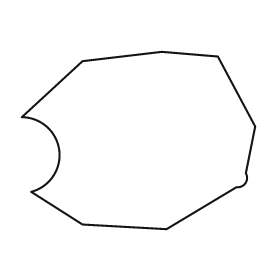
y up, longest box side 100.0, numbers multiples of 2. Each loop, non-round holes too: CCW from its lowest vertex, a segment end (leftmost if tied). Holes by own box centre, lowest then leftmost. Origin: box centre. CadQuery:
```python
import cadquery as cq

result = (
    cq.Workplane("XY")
    .moveTo(12.0, -38.0)
    .lineTo(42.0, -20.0)
    .threePointArc((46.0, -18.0), (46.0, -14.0))
    .lineTo(50.0, 6.0)
    .lineTo(34.0, 36.0)
    .lineTo(10.0, 38.0)
    .lineTo(-24.0, 34.0)
    .lineTo(-50.0, 10.0)
    .threePointArc((-34.0, -4.0), (-46.0, -22.0))
    .lineTo(-24.0, -36.0)
    .close()
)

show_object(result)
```